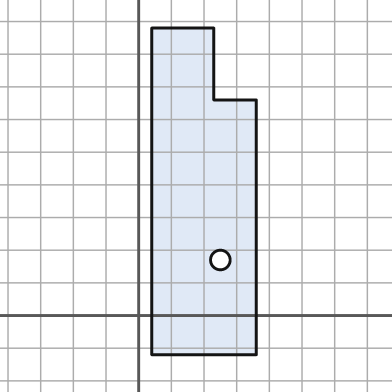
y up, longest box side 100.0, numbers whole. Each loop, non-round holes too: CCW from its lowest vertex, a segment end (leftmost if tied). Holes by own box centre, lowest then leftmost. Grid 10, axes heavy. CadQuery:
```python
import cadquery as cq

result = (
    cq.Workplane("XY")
    .moveTo(4.0, -12.0)
    .lineTo(36.0, -12.0)
    .lineTo(36.0, 66.0)
    .lineTo(23.0, 66.0)
    .lineTo(23.0, 88.0)
    .lineTo(4.0, 88.0)
    .close()
    .moveTo(25.0, 17.0)
    .circle(3.0)
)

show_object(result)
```